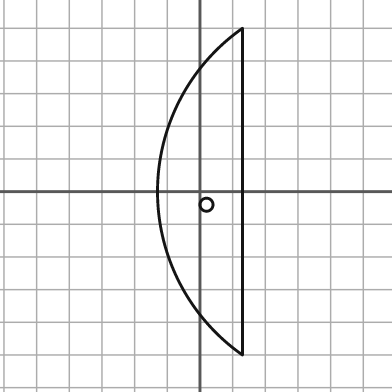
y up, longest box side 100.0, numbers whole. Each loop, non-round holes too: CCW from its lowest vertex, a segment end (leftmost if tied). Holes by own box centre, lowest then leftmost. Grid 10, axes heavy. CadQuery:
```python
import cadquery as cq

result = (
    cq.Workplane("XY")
    .moveTo(13.0, -50.0)
    .lineTo(13.0, 50.0)
    .threePointArc((-13.0, 0.0), (13.0, -50.0))
    .close()
    .moveTo(2.0, -4.0)
    .circle(2.0)
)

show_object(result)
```